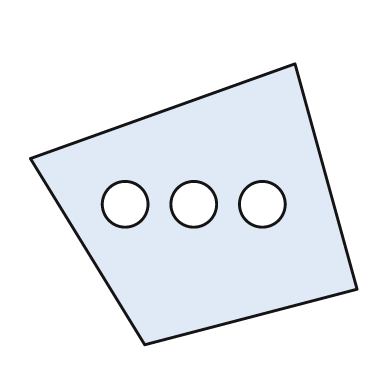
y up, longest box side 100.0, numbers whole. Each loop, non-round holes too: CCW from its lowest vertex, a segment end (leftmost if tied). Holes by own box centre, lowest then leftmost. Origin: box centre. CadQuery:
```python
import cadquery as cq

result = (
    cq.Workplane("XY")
    .moveTo(-15.0, -43.0)
    .lineTo(50.0, -26.0)
    .lineTo(31.0, 43.0)
    .lineTo(-50.0, 14.0)
    .close()
    .moveTo(-21.0, 0.0)
    .circle(7.0)
    .moveTo(0.0, 0.0)
    .circle(7.0)
    .moveTo(21.0, 0.0)
    .circle(7.0)
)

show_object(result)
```